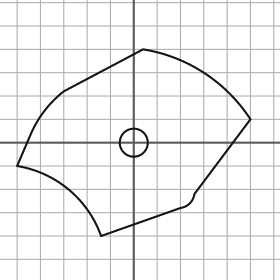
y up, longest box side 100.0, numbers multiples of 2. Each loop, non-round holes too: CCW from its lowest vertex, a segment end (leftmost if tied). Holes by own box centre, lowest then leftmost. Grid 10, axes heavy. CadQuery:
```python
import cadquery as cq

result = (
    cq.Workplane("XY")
    .moveTo(-14.0, -40.0)
    .lineTo(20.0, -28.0)
    .threePointArc((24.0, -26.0), (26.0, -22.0))
    .lineTo(50.0, 10.0)
    .threePointArc((30.0, 30.0), (4.0, 40.0))
    .lineTo(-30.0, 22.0)
    .threePointArc((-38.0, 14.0), (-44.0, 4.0))
    .lineTo(-50.0, -10.0)
    .threePointArc((-28.0, -20.0), (-14.0, -40.0))
    .close()
    .moveTo(0.0, 0.0)
    .circle(6.0)
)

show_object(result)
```